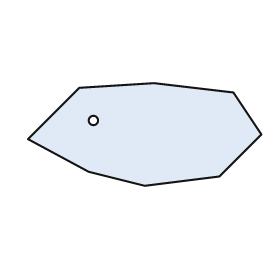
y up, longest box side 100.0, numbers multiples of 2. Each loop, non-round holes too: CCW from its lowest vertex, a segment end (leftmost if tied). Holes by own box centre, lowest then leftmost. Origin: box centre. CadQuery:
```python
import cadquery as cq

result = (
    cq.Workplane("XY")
    .moveTo(0.0, -22.0)
    .lineTo(32.0, -18.0)
    .lineTo(50.0, 0.0)
    .lineTo(38.0, 18.0)
    .lineTo(4.0, 22.0)
    .lineTo(-28.0, 20.0)
    .lineTo(-50.0, -2.0)
    .lineTo(-24.0, -16.0)
    .close()
    .moveTo(-22.0, 6.0)
    .circle(2.0)
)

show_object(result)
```